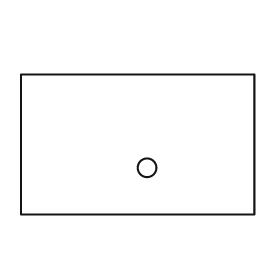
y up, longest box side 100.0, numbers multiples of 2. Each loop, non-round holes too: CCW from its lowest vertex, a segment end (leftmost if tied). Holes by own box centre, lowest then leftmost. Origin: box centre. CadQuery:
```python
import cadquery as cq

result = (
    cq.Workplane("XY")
    .moveTo(-50.0, -30.0)
    .lineTo(50.0, -30.0)
    .lineTo(50.0, 30.0)
    .lineTo(-50.0, 30.0)
    .close()
    .moveTo(4.0, -10.0)
    .circle(4.0)
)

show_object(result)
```